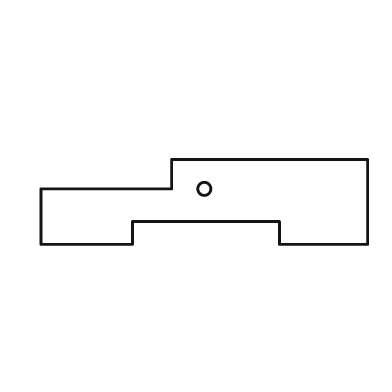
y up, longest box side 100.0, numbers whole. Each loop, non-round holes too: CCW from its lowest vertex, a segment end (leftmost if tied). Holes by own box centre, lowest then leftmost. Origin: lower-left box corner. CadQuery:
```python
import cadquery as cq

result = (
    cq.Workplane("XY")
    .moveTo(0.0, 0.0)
    .lineTo(28.0, 0.0)
    .lineTo(28.0, 7.0)
    .lineTo(73.0, 7.0)
    .lineTo(73.0, 0.0)
    .lineTo(100.0, 0.0)
    .lineTo(100.0, 26.0)
    .lineTo(40.0, 26.0)
    .lineTo(40.0, 17.0)
    .lineTo(0.0, 17.0)
    .close()
    .moveTo(50.0, 17.0)
    .circle(2.0)
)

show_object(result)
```